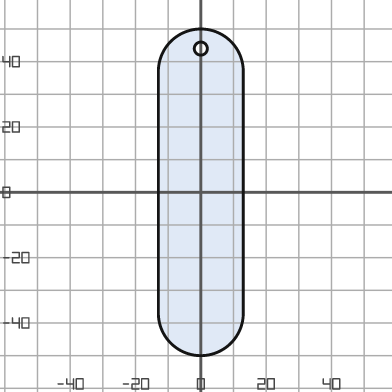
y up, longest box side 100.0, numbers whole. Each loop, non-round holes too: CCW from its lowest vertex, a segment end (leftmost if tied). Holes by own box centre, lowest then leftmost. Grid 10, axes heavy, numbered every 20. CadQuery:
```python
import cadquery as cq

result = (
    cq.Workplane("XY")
    .moveTo(-13.0, -37.0)
    .threePointArc((0.0, -50.0), (13.0, -37.0))
    .lineTo(13.0, 37.0)
    .threePointArc((0.0, 50.0), (-13.0, 37.0))
    .close()
    .moveTo(0.0, 44.0)
    .circle(2.0)
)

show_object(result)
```